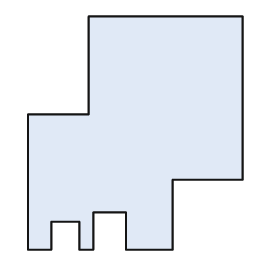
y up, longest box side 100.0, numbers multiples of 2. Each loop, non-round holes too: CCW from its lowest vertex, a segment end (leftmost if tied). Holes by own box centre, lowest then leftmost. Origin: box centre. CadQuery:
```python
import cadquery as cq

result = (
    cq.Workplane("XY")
    .moveTo(-46.0, -50.0)
    .lineTo(-36.0, -50.0)
    .lineTo(-36.0, -38.0)
    .lineTo(-24.0, -38.0)
    .lineTo(-24.0, -50.0)
    .lineTo(-18.0, -50.0)
    .lineTo(-18.0, -34.0)
    .lineTo(-4.0, -34.0)
    .lineTo(-4.0, -50.0)
    .lineTo(16.0, -50.0)
    .lineTo(16.0, -20.0)
    .lineTo(46.0, -20.0)
    .lineTo(46.0, 50.0)
    .lineTo(-20.0, 50.0)
    .lineTo(-20.0, 8.0)
    .lineTo(-46.0, 8.0)
    .close()
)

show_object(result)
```